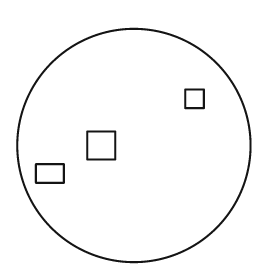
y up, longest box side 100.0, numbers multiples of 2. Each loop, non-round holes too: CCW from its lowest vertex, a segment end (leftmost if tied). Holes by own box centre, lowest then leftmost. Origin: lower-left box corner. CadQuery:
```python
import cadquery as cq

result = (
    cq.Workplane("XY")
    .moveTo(50.0, 50.0)
    .circle(50.0)
    .moveTo(8.0, 34.0)
    .lineTo(20.0, 34.0)
    .lineTo(20.0, 42.0)
    .lineTo(8.0, 42.0)
    .close()
    .moveTo(30.0, 44.0)
    .lineTo(42.0, 44.0)
    .lineTo(42.0, 56.0)
    .lineTo(30.0, 56.0)
    .close()
    .moveTo(72.0, 66.0)
    .lineTo(80.0, 66.0)
    .lineTo(80.0, 74.0)
    .lineTo(72.0, 74.0)
    .close()
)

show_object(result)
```